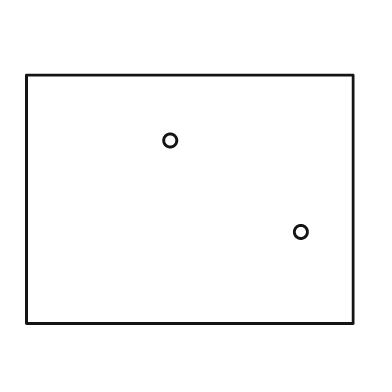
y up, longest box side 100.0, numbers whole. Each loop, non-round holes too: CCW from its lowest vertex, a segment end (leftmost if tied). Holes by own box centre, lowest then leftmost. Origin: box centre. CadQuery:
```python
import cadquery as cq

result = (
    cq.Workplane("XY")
    .moveTo(-50.0, -38.0)
    .lineTo(50.0, -38.0)
    .lineTo(50.0, 38.0)
    .lineTo(-50.0, 38.0)
    .close()
    .moveTo(34.0, -10.0)
    .circle(2.0)
    .moveTo(-6.0, 18.0)
    .circle(2.0)
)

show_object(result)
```